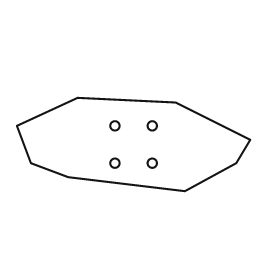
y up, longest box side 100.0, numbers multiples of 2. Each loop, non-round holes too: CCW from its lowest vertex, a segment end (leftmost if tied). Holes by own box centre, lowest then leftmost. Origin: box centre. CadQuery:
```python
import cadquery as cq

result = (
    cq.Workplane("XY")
    .moveTo(22.0, -20.0)
    .lineTo(44.0, -8.0)
    .lineTo(50.0, 2.0)
    .lineTo(18.0, 18.0)
    .lineTo(-24.0, 20.0)
    .lineTo(-50.0, 8.0)
    .lineTo(-44.0, -8.0)
    .lineTo(-28.0, -14.0)
    .close()
    .moveTo(-8.0, -8.0)
    .circle(2.0)
    .moveTo(8.0, -8.0)
    .circle(2.0)
    .moveTo(-8.0, 8.0)
    .circle(2.0)
    .moveTo(8.0, 8.0)
    .circle(2.0)
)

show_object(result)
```